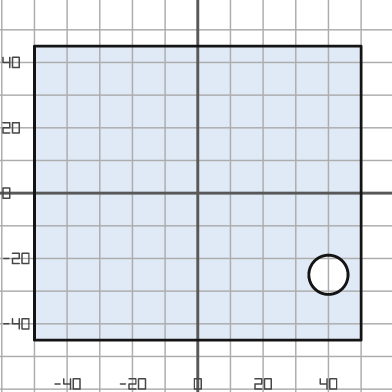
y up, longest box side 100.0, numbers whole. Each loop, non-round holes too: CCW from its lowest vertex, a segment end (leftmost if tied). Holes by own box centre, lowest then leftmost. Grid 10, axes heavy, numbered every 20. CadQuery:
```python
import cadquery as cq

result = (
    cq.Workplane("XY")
    .moveTo(-50.0, -45.0)
    .lineTo(50.0, -45.0)
    .lineTo(50.0, 45.0)
    .lineTo(-50.0, 45.0)
    .close()
    .moveTo(40.0, -25.0)
    .circle(6.0)
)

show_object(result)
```